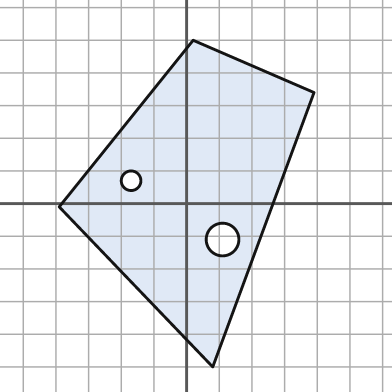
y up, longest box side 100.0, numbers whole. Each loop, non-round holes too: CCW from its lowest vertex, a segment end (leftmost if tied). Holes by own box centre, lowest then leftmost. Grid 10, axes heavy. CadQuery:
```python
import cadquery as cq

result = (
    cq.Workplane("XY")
    .moveTo(8.0, -50.0)
    .lineTo(39.0, 34.0)
    .lineTo(2.0, 50.0)
    .lineTo(-39.0, -1.0)
    .close()
    .moveTo(11.0, -11.0)
    .circle(5.0)
    .moveTo(-17.0, 7.0)
    .circle(3.0)
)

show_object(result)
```